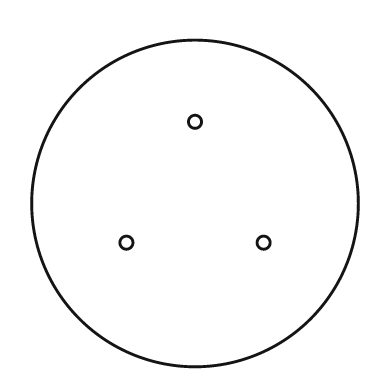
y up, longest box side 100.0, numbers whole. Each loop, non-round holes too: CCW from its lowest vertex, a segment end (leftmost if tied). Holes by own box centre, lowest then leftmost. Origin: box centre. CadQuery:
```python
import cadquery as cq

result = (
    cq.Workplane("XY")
    .moveTo(0.0, 0.0)
    .circle(50.0)
    .moveTo(-21.0, -12.0)
    .circle(2.0)
    .moveTo(21.0, -12.0)
    .circle(2.0)
    .moveTo(0.0, 25.0)
    .circle(2.0)
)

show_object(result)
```